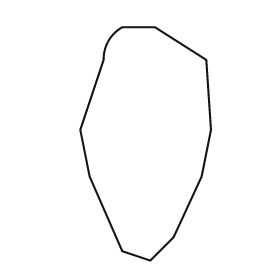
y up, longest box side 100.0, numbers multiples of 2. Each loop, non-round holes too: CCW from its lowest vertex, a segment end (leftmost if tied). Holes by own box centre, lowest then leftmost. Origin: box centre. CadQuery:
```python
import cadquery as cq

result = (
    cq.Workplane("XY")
    .moveTo(2.0, -50.0)
    .lineTo(12.0, -40.0)
    .lineTo(24.0, -14.0)
    .lineTo(28.0, 6.0)
    .lineTo(26.0, 36.0)
    .lineTo(4.0, 50.0)
    .lineTo(-10.0, 50.0)
    .threePointArc((-16.0, 44.0), (-18.0, 36.0))
    .lineTo(-28.0, 6.0)
    .lineTo(-24.0, -14.0)
    .lineTo(-10.0, -46.0)
    .close()
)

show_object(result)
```